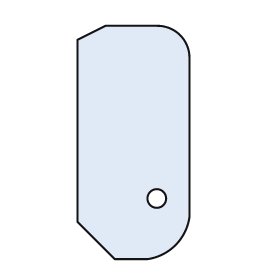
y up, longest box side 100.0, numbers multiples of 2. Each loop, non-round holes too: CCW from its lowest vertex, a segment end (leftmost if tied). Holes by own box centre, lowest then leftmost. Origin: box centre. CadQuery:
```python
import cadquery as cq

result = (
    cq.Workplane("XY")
    .moveTo(-8.0, -50.0)
    .lineTo(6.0, -50.0)
    .threePointArc((18.0, -44.0), (24.0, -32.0))
    .lineTo(24.0, 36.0)
    .threePointArc((20.0, 46.0), (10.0, 50.0))
    .lineTo(-12.0, 50.0)
    .lineTo(-24.0, 44.0)
    .lineTo(-24.0, -34.0)
    .close()
    .moveTo(10.0, -24.0)
    .circle(4.0)
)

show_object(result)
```